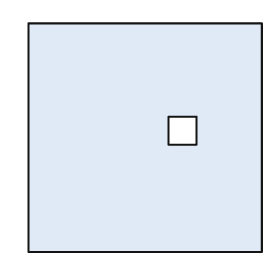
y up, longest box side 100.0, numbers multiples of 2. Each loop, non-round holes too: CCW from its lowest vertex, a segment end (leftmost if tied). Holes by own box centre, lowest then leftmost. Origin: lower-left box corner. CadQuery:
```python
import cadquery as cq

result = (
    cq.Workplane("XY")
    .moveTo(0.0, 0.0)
    .lineTo(100.0, 0.0)
    .lineTo(100.0, 98.0)
    .lineTo(0.0, 98.0)
    .close()
    .moveTo(60.0, 46.0)
    .lineTo(72.0, 46.0)
    .lineTo(72.0, 58.0)
    .lineTo(60.0, 58.0)
    .close()
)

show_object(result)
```